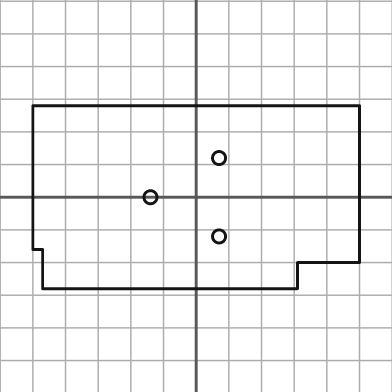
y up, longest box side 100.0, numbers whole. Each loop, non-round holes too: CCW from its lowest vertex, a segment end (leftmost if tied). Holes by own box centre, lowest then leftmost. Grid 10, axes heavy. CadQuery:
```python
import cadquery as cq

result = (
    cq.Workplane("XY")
    .moveTo(-47.0, -28.0)
    .lineTo(31.0, -28.0)
    .lineTo(31.0, -20.0)
    .lineTo(50.0, -20.0)
    .lineTo(50.0, 28.0)
    .lineTo(-50.0, 28.0)
    .lineTo(-50.0, -16.0)
    .lineTo(-47.0, -16.0)
    .close()
    .moveTo(7.0, -12.0)
    .circle(2.0)
    .moveTo(-14.0, 0.0)
    .circle(2.0)
    .moveTo(7.0, 12.0)
    .circle(2.0)
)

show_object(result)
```